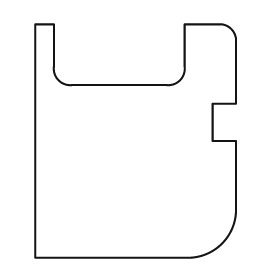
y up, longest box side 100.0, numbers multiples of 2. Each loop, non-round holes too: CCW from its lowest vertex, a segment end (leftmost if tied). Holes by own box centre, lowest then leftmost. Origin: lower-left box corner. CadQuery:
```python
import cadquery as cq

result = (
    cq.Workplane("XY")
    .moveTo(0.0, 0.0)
    .lineTo(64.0, 0.0)
    .threePointArc((80.0, 6.0), (86.0, 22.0))
    .lineTo(86.0, 50.0)
    .lineTo(76.0, 50.0)
    .lineTo(76.0, 66.0)
    .lineTo(86.0, 66.0)
    .lineTo(86.0, 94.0)
    .threePointArc((84.0, 98.0), (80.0, 100.0))
    .lineTo(64.0, 100.0)
    .lineTo(64.0, 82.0)
    .threePointArc((62.0, 76.0), (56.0, 74.0))
    .lineTo(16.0, 74.0)
    .threePointArc((10.0, 76.0), (8.0, 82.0))
    .lineTo(8.0, 100.0)
    .lineTo(0.0, 100.0)
    .close()
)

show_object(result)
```